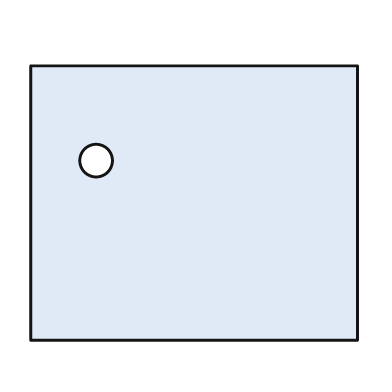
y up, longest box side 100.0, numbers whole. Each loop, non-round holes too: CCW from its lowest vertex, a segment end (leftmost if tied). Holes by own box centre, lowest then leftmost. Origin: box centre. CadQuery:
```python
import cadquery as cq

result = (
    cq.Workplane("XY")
    .moveTo(-50.0, -42.0)
    .lineTo(50.0, -42.0)
    .lineTo(50.0, 42.0)
    .lineTo(-50.0, 42.0)
    .close()
    .moveTo(-30.0, 13.0)
    .circle(5.0)
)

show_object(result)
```